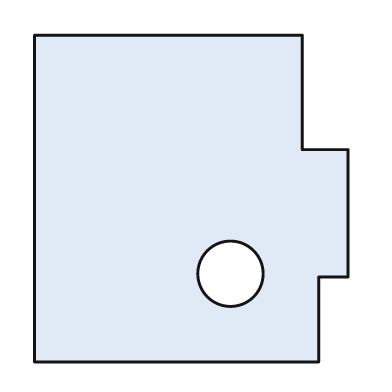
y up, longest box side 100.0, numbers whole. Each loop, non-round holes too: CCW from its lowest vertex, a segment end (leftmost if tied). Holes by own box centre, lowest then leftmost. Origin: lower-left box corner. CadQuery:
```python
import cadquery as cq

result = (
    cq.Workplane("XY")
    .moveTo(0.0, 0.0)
    .lineTo(87.0, 0.0)
    .lineTo(87.0, 26.0)
    .lineTo(96.0, 26.0)
    .lineTo(96.0, 65.0)
    .lineTo(82.0, 65.0)
    .lineTo(82.0, 100.0)
    .lineTo(0.0, 100.0)
    .close()
    .moveTo(60.0, 27.0)
    .circle(10.0)
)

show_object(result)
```